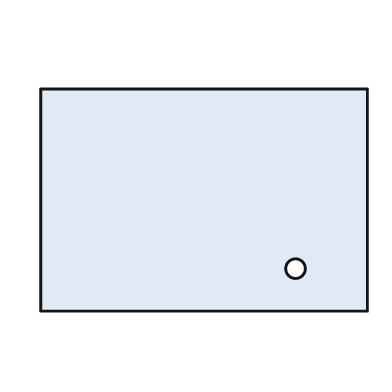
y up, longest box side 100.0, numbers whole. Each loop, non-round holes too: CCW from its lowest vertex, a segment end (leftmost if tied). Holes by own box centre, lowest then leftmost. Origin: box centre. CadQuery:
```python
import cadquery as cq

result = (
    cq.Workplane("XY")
    .moveTo(-50.0, -34.0)
    .lineTo(50.0, -34.0)
    .lineTo(50.0, 34.0)
    .lineTo(-50.0, 34.0)
    .close()
    .moveTo(28.0, -21.0)
    .circle(3.0)
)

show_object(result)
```